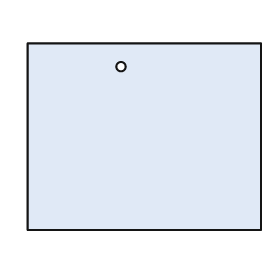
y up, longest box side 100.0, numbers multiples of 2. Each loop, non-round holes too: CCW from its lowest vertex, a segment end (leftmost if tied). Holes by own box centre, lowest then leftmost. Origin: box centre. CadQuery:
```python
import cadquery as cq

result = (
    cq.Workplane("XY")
    .moveTo(-50.0, -40.0)
    .lineTo(50.0, -40.0)
    .lineTo(50.0, 40.0)
    .lineTo(-50.0, 40.0)
    .close()
    .moveTo(-10.0, 30.0)
    .circle(2.0)
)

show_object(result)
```